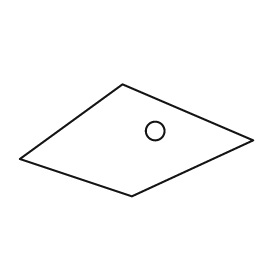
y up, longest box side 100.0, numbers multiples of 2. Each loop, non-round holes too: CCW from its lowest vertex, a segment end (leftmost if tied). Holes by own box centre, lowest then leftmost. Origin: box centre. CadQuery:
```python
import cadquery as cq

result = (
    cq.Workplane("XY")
    .moveTo(-2.0, -24.0)
    .lineTo(50.0, 0.0)
    .lineTo(-6.0, 24.0)
    .lineTo(-50.0, -8.0)
    .close()
    .moveTo(8.0, 4.0)
    .circle(4.0)
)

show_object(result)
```